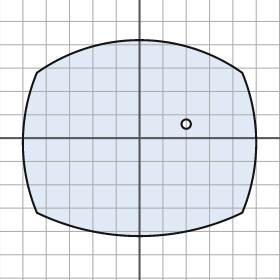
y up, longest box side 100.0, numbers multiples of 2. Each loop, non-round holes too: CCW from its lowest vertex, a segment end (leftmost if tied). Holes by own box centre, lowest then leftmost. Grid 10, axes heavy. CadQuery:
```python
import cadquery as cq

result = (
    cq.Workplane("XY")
    .moveTo(-44.0, -32.0)
    .threePointArc((0.0, -42.0), (44.0, -32.0))
    .threePointArc((50.0, -2.0), (44.0, 28.0))
    .threePointArc((0.0, 42.0), (-44.0, 28.0))
    .threePointArc((-50.0, -2.0), (-44.0, -32.0))
    .close()
    .moveTo(20.0, 6.0)
    .circle(2.0)
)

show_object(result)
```